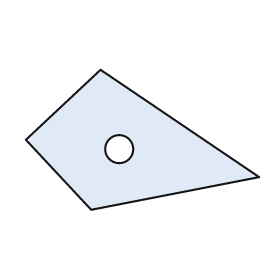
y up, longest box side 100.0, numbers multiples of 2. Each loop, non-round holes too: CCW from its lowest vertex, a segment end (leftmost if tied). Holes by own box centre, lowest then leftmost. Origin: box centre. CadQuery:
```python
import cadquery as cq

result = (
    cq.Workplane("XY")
    .moveTo(-22.0, -30.0)
    .lineTo(50.0, -16.0)
    .lineTo(-18.0, 30.0)
    .lineTo(-50.0, 0.0)
    .close()
    .moveTo(-10.0, -4.0)
    .circle(6.0)
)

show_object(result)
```